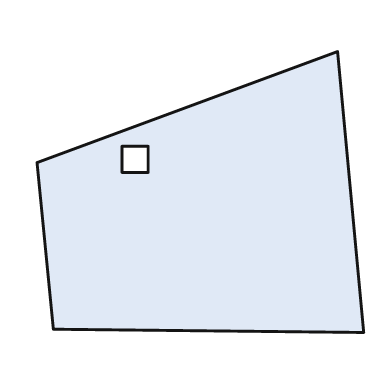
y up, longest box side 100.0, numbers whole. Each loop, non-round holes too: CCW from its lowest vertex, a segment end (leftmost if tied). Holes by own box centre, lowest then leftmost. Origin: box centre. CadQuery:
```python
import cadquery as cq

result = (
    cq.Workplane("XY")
    .moveTo(50.0, -43.0)
    .lineTo(42.0, 43.0)
    .lineTo(-50.0, 9.0)
    .lineTo(-45.0, -42.0)
    .close()
    .moveTo(-24.0, 6.0)
    .lineTo(-16.0, 6.0)
    .lineTo(-16.0, 14.0)
    .lineTo(-24.0, 14.0)
    .close()
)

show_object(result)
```